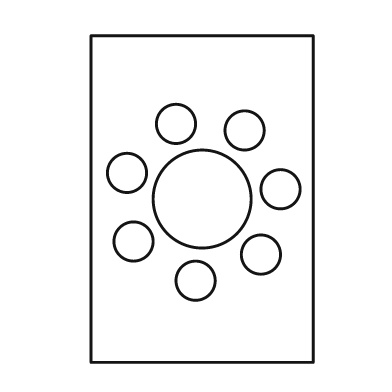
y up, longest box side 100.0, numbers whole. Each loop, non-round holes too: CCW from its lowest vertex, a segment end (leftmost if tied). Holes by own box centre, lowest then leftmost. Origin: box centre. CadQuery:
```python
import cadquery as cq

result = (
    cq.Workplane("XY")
    .moveTo(-34.0, -50.0)
    .lineTo(34.0, -50.0)
    .lineTo(34.0, 50.0)
    .lineTo(-34.0, 50.0)
    .close()
    .moveTo(-2.0, -25.0)
    .circle(6.0)
    .moveTo(18.0, -17.0)
    .circle(6.0)
    .moveTo(-21.0, -13.0)
    .circle(6.0)
    .moveTo(0.0, 0.0)
    .circle(15.0)
    .moveTo(24.0, 3.0)
    .circle(6.0)
    .moveTo(-23.0, 8.0)
    .circle(6.0)
    .moveTo(13.0, 21.0)
    .circle(6.0)
    .moveTo(-8.0, 23.0)
    .circle(6.0)
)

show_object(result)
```